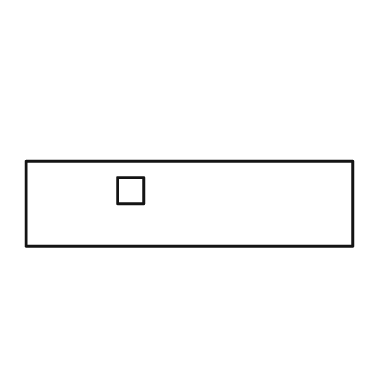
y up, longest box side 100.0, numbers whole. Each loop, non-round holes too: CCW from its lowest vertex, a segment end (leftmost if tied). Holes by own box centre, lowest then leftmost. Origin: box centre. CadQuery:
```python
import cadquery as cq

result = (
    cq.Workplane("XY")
    .moveTo(-50.0, -13.0)
    .lineTo(50.0, -13.0)
    .lineTo(50.0, 13.0)
    .lineTo(-50.0, 13.0)
    .close()
    .moveTo(-22.0, 0.0)
    .lineTo(-14.0, 0.0)
    .lineTo(-14.0, 8.0)
    .lineTo(-22.0, 8.0)
    .close()
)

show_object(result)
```